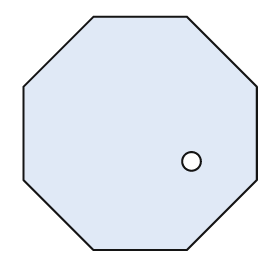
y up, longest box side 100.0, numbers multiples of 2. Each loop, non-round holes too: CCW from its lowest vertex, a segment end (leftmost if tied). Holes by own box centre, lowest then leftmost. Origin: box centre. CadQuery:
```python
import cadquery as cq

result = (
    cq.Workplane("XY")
    .moveTo(-20.0, -50.0)
    .lineTo(20.0, -50.0)
    .lineTo(50.0, -20.0)
    .lineTo(50.0, 20.0)
    .lineTo(20.0, 50.0)
    .lineTo(-20.0, 50.0)
    .lineTo(-50.0, 20.0)
    .lineTo(-50.0, -20.0)
    .close()
    .moveTo(22.0, -12.0)
    .circle(4.0)
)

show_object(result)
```